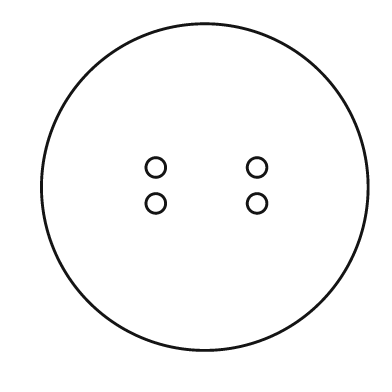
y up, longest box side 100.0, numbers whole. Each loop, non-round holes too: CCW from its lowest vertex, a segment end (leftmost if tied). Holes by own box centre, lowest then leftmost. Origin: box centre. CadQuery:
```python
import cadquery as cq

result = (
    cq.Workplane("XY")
    .moveTo(0.0, 0.0)
    .circle(50.0)
    .moveTo(-15.0, -5.0)
    .circle(3.0)
    .moveTo(16.0, -5.0)
    .circle(3.0)
    .moveTo(-15.0, 6.0)
    .circle(3.0)
    .moveTo(16.0, 6.0)
    .circle(3.0)
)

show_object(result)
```